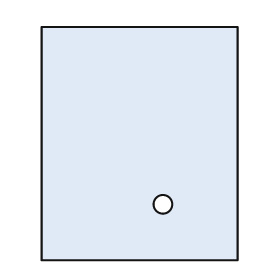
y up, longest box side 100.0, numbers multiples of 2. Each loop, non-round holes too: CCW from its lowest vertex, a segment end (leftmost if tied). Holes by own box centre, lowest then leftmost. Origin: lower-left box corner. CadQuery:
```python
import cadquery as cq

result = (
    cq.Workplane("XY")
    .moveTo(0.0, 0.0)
    .lineTo(84.0, 0.0)
    .lineTo(84.0, 100.0)
    .lineTo(0.0, 100.0)
    .close()
    .moveTo(52.0, 24.0)
    .circle(4.0)
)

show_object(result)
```